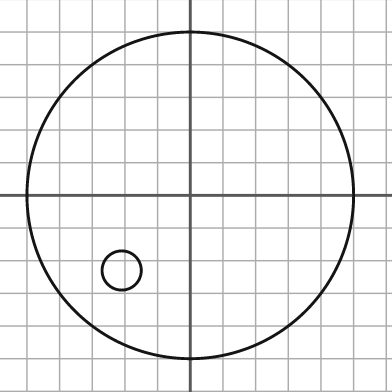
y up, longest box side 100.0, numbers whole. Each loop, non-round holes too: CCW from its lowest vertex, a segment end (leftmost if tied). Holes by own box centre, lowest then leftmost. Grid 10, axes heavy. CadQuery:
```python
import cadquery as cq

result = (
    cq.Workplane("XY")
    .moveTo(0.0, 0.0)
    .circle(50.0)
    .moveTo(-21.0, -23.0)
    .circle(6.0)
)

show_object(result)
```